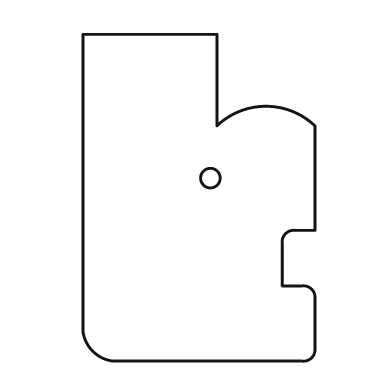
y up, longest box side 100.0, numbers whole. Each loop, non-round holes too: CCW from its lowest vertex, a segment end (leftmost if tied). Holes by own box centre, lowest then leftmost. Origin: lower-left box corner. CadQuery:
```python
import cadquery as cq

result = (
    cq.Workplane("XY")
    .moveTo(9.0, 0.0)
    .lineTo(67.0, 0.0)
    .threePointArc((70.0, 1.0), (71.0, 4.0))
    .lineTo(71.0, 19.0)
    .threePointArc((70.0, 22.0), (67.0, 23.0))
    .lineTo(61.0, 23.0)
    .lineTo(61.0, 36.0)
    .threePointArc((62.0, 39.0), (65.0, 40.0))
    .lineTo(71.0, 40.0)
    .lineTo(71.0, 72.0)
    .threePointArc((56.0, 78.0), (41.0, 72.0))
    .lineTo(41.0, 100.0)
    .lineTo(0.0, 100.0)
    .lineTo(0.0, 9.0)
    .threePointArc((3.0, 3.0), (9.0, 0.0))
    .close()
    .moveTo(39.0, 56.0)
    .circle(3.0)
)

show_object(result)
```